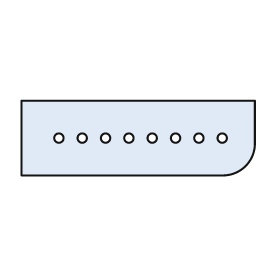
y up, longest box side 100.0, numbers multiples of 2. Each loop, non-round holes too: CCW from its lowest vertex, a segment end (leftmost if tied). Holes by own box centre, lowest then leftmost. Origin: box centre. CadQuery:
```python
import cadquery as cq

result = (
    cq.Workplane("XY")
    .moveTo(-50.0, -16.0)
    .lineTo(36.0, -16.0)
    .threePointArc((46.0, -12.0), (50.0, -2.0))
    .lineTo(50.0, 16.0)
    .lineTo(-50.0, 16.0)
    .close()
    .moveTo(-34.0, 0.0)
    .circle(2.0)
    .moveTo(-24.0, 0.0)
    .circle(2.0)
    .moveTo(-14.0, 0.0)
    .circle(2.0)
    .moveTo(-4.0, 0.0)
    .circle(2.0)
    .moveTo(6.0, 0.0)
    .circle(2.0)
    .moveTo(16.0, 0.0)
    .circle(2.0)
    .moveTo(26.0, 0.0)
    .circle(2.0)
    .moveTo(36.0, 0.0)
    .circle(2.0)
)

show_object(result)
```